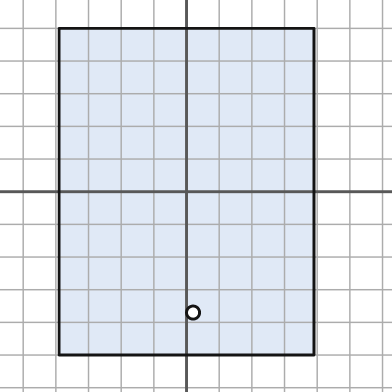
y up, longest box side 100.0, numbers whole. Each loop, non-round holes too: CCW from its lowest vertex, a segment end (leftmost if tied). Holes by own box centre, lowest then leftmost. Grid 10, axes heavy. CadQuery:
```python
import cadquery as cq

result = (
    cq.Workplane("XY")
    .moveTo(-39.0, -50.0)
    .lineTo(39.0, -50.0)
    .lineTo(39.0, 50.0)
    .lineTo(-39.0, 50.0)
    .close()
    .moveTo(2.0, -37.0)
    .circle(2.0)
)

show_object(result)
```